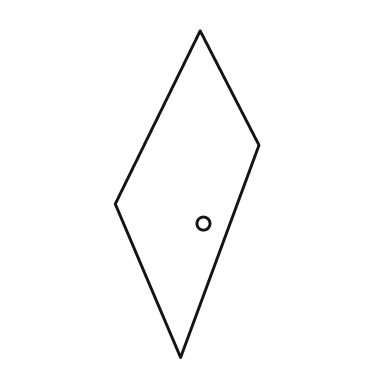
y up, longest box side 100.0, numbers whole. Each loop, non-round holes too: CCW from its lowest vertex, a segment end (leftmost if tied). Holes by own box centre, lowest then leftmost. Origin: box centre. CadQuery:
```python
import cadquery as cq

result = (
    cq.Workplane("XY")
    .moveTo(-2.0, -50.0)
    .lineTo(22.0, 15.0)
    .lineTo(4.0, 50.0)
    .lineTo(-22.0, -3.0)
    .close()
    .moveTo(5.0, -9.0)
    .circle(2.0)
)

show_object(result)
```